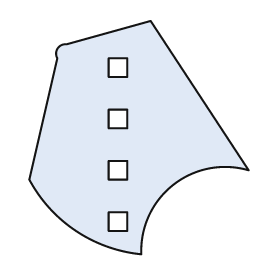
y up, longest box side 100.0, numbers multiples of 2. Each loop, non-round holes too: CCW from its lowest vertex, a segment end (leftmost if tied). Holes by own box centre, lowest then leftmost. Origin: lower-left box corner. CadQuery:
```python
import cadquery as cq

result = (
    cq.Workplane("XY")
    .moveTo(48.0, 0.0)
    .threePointArc((62.0, 30.0), (94.0, 36.0))
    .lineTo(52.0, 100.0)
    .lineTo(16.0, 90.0)
    .threePointArc((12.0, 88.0), (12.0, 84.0))
    .lineTo(0.0, 32.0)
    .threePointArc((20.0, 10.0), (48.0, 0.0))
    .close()
    .moveTo(34.0, 10.0)
    .lineTo(42.0, 10.0)
    .lineTo(42.0, 18.0)
    .lineTo(34.0, 18.0)
    .close()
    .moveTo(34.0, 32.0)
    .lineTo(42.0, 32.0)
    .lineTo(42.0, 40.0)
    .lineTo(34.0, 40.0)
    .close()
    .moveTo(34.0, 54.0)
    .lineTo(42.0, 54.0)
    .lineTo(42.0, 62.0)
    .lineTo(34.0, 62.0)
    .close()
    .moveTo(34.0, 76.0)
    .lineTo(42.0, 76.0)
    .lineTo(42.0, 84.0)
    .lineTo(34.0, 84.0)
    .close()
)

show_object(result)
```